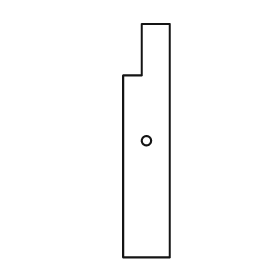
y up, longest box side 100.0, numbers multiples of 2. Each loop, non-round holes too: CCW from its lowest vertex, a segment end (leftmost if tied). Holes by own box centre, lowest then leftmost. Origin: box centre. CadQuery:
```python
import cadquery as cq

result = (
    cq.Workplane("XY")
    .moveTo(-10.0, -50.0)
    .lineTo(10.0, -50.0)
    .lineTo(10.0, 50.0)
    .lineTo(-2.0, 50.0)
    .lineTo(-2.0, 28.0)
    .lineTo(-10.0, 28.0)
    .close()
    .moveTo(0.0, 0.0)
    .circle(2.0)
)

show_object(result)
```